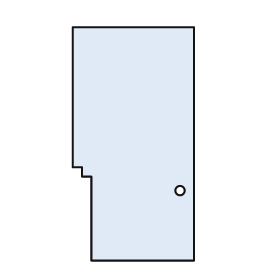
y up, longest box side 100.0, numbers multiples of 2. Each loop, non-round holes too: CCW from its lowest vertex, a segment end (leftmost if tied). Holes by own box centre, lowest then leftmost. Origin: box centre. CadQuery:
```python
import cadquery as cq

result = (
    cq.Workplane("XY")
    .moveTo(-18.0, -50.0)
    .lineTo(26.0, -50.0)
    .lineTo(26.0, 50.0)
    .lineTo(-26.0, 50.0)
    .lineTo(-26.0, -10.0)
    .lineTo(-22.0, -10.0)
    .lineTo(-22.0, -14.0)
    .lineTo(-18.0, -14.0)
    .close()
    .moveTo(20.0, -20.0)
    .circle(2.0)
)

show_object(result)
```